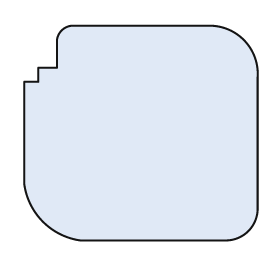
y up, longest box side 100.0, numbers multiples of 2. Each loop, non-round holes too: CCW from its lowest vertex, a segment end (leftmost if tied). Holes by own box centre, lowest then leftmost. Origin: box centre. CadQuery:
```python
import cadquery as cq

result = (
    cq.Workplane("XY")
    .moveTo(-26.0, -46.0)
    .lineTo(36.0, -46.0)
    .threePointArc((46.0, -42.0), (50.0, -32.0))
    .lineTo(50.0, 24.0)
    .threePointArc((44.0, 40.0), (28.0, 46.0))
    .lineTo(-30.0, 46.0)
    .threePointArc((-34.0, 44.0), (-36.0, 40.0))
    .lineTo(-36.0, 28.0)
    .lineTo(-44.0, 28.0)
    .lineTo(-44.0, 22.0)
    .lineTo(-50.0, 22.0)
    .lineTo(-50.0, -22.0)
    .threePointArc((-42.0, -38.0), (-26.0, -46.0))
    .close()
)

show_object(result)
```